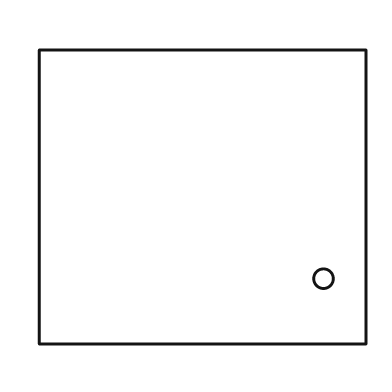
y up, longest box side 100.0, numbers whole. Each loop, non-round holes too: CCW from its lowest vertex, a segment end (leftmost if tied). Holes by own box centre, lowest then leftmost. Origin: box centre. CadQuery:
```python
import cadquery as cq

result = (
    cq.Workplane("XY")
    .moveTo(-50.0, -45.0)
    .lineTo(50.0, -45.0)
    .lineTo(50.0, 45.0)
    .lineTo(-50.0, 45.0)
    .close()
    .moveTo(37.0, -25.0)
    .circle(3.0)
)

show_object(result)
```